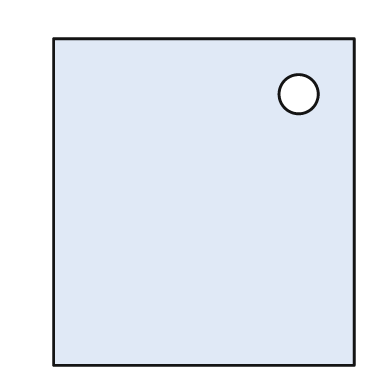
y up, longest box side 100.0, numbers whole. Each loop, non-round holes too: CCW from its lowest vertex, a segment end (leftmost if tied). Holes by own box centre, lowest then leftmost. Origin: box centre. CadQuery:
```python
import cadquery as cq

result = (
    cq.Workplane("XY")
    .moveTo(-46.0, -50.0)
    .lineTo(46.0, -50.0)
    .lineTo(46.0, 50.0)
    .lineTo(-46.0, 50.0)
    .close()
    .moveTo(29.0, 33.0)
    .circle(6.0)
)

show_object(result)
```